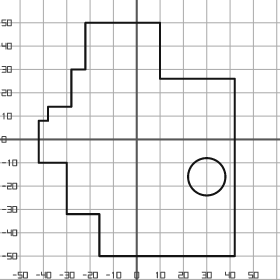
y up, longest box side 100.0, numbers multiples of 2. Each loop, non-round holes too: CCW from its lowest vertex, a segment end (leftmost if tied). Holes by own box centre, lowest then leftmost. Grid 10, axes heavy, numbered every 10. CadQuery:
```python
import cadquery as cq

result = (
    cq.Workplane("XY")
    .moveTo(-16.0, -50.0)
    .lineTo(42.0, -50.0)
    .lineTo(42.0, 26.0)
    .lineTo(10.0, 26.0)
    .lineTo(10.0, 50.0)
    .lineTo(-22.0, 50.0)
    .lineTo(-22.0, 30.0)
    .lineTo(-28.0, 30.0)
    .lineTo(-28.0, 14.0)
    .lineTo(-38.0, 14.0)
    .lineTo(-38.0, 8.0)
    .lineTo(-42.0, 8.0)
    .lineTo(-42.0, -10.0)
    .lineTo(-30.0, -10.0)
    .lineTo(-30.0, -32.0)
    .lineTo(-16.0, -32.0)
    .close()
    .moveTo(30.0, -16.0)
    .circle(8.0)
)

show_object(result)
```